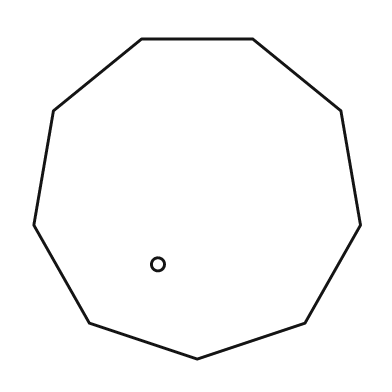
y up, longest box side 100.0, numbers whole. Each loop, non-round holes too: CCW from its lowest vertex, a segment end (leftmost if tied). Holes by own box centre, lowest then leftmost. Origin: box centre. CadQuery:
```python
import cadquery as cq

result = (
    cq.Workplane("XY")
    .moveTo(0.0, -49.0)
    .lineTo(33.0, -38.0)
    .lineTo(50.0, -8.0)
    .lineTo(44.0, 27.0)
    .lineTo(17.0, 49.0)
    .lineTo(-17.0, 49.0)
    .lineTo(-44.0, 27.0)
    .lineTo(-50.0, -8.0)
    .lineTo(-33.0, -38.0)
    .close()
    .moveTo(-12.0, -20.0)
    .circle(2.0)
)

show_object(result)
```